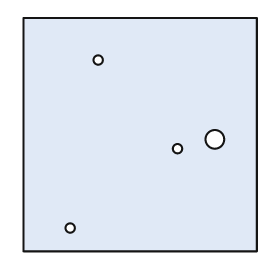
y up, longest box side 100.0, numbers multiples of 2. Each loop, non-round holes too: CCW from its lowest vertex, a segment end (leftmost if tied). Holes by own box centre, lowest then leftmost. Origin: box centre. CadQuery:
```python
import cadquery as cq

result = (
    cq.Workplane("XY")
    .moveTo(-50.0, -50.0)
    .lineTo(50.0, -50.0)
    .lineTo(50.0, 50.0)
    .lineTo(-50.0, 50.0)
    .close()
    .moveTo(-30.0, -40.0)
    .circle(2.0)
    .moveTo(16.0, -6.0)
    .circle(2.0)
    .moveTo(32.0, -2.0)
    .circle(4.0)
    .moveTo(-18.0, 32.0)
    .circle(2.0)
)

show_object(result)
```